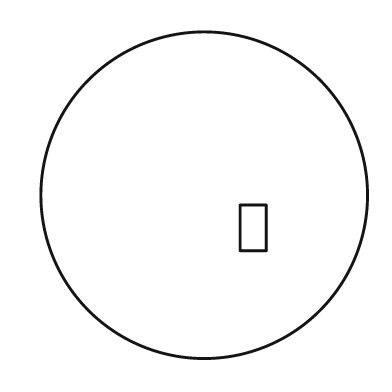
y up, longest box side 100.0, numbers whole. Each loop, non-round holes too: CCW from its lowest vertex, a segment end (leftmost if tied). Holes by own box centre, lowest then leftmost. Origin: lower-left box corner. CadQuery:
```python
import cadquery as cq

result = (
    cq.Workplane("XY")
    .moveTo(50.0, 50.0)
    .circle(50.0)
    .moveTo(61.0, 33.0)
    .lineTo(69.0, 33.0)
    .lineTo(69.0, 47.0)
    .lineTo(61.0, 47.0)
    .close()
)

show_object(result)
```